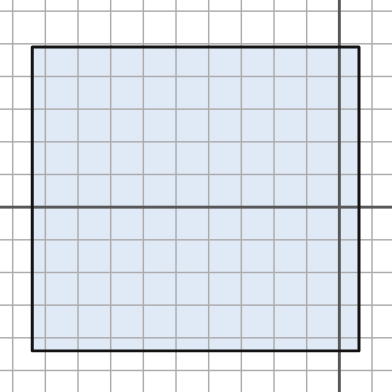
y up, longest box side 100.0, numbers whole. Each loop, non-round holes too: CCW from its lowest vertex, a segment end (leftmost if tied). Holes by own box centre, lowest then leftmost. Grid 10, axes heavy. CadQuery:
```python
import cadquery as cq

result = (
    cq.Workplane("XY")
    .moveTo(-94.0, -44.0)
    .lineTo(6.0, -44.0)
    .lineTo(6.0, 49.0)
    .lineTo(-94.0, 49.0)
    .close()
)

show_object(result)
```